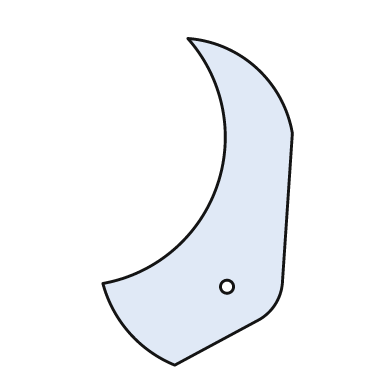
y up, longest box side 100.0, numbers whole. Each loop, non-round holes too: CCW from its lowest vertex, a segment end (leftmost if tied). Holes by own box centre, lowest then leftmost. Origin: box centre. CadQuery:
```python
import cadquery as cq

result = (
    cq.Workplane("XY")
    .moveTo(-7.0, -50.0)
    .lineTo(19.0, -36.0)
    .threePointArc((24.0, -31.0), (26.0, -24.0))
    .lineTo(29.0, 21.0)
    .threePointArc((18.0, 41.0), (-3.0, 50.0))
    .threePointArc((6.0, 5.0), (-29.0, -25.0))
    .threePointArc((-21.0, -40.0), (-7.0, -50.0))
    .close()
    .moveTo(9.0, -26.0)
    .circle(2.0)
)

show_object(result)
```